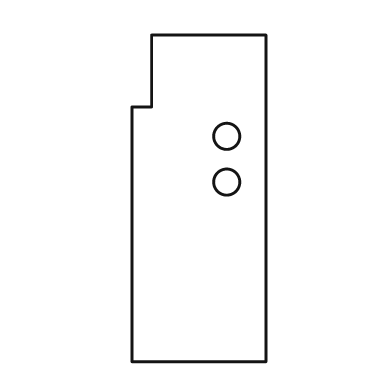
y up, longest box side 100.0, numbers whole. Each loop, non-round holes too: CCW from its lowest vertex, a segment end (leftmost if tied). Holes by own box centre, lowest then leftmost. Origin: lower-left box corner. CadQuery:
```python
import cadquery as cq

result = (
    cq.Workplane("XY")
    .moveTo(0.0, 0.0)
    .lineTo(41.0, 0.0)
    .lineTo(41.0, 100.0)
    .lineTo(6.0, 100.0)
    .lineTo(6.0, 78.0)
    .lineTo(0.0, 78.0)
    .close()
    .moveTo(29.0, 55.0)
    .circle(4.0)
    .moveTo(29.0, 69.0)
    .circle(4.0)
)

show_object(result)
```